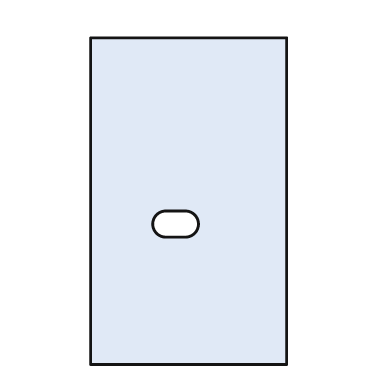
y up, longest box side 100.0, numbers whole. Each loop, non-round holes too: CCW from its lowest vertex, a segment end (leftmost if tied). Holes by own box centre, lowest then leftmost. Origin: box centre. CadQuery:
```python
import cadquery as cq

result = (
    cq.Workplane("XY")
    .moveTo(-30.0, -50.0)
    .lineTo(30.0, -50.0)
    .lineTo(30.0, 50.0)
    .lineTo(-30.0, 50.0)
    .close()
    .moveTo(-7.0, -11.0)
    .lineTo(-1.0, -11.0)
    .threePointArc((3.0, -7.0), (-1.0, -3.0))
    .lineTo(-7.0, -3.0)
    .threePointArc((-11.0, -7.0), (-7.0, -11.0))
    .close()
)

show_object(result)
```